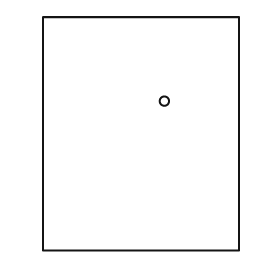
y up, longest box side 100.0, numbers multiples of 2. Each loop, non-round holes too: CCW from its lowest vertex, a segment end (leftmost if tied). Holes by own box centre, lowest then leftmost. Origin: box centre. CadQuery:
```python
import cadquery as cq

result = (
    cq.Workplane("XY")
    .moveTo(-42.0, -50.0)
    .lineTo(42.0, -50.0)
    .lineTo(42.0, 50.0)
    .lineTo(-42.0, 50.0)
    .close()
    .moveTo(10.0, 14.0)
    .circle(2.0)
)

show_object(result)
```